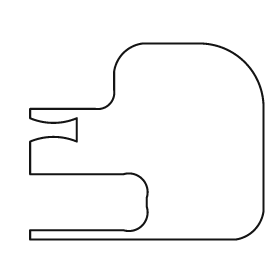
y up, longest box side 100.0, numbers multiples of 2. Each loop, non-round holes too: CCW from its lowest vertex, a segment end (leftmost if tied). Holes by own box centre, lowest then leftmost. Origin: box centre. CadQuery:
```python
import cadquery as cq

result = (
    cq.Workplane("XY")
    .moveTo(-50.0, -42.0)
    .lineTo(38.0, -42.0)
    .threePointArc((46.0, -38.0), (50.0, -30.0))
    .lineTo(50.0, 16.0)
    .threePointArc((42.0, 34.0), (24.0, 42.0))
    .lineTo(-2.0, 42.0)
    .threePointArc((-10.0, 38.0), (-14.0, 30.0))
    .lineTo(-14.0, 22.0)
    .threePointArc((-16.0, 16.0), (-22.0, 14.0))
    .lineTo(-50.0, 14.0)
    .lineTo(-50.0, 10.0)
    .threePointArc((-40.0, 8.0), (-30.0, 10.0))
    .lineTo(-30.0, 0.0)
    .threePointArc((-40.0, 2.0), (-50.0, 0.0))
    .lineTo(-50.0, -14.0)
    .lineTo(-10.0, -14.0)
    .threePointArc((-2.0, -16.0), (0.0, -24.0))
    .lineTo(0.0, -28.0)
    .threePointArc((-2.0, -36.0), (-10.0, -38.0))
    .lineTo(-50.0, -38.0)
    .close()
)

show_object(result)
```